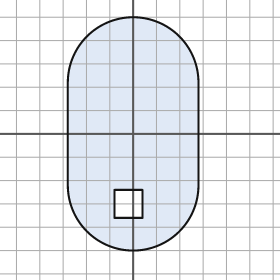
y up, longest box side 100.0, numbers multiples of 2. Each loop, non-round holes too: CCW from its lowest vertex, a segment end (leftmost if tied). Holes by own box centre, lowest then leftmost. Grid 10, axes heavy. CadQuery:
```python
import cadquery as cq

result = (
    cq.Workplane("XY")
    .moveTo(-28.0, -22.0)
    .threePointArc((0.0, -50.0), (28.0, -22.0))
    .lineTo(28.0, 22.0)
    .threePointArc((0.0, 50.0), (-28.0, 22.0))
    .close()
    .moveTo(-8.0, -36.0)
    .lineTo(4.0, -36.0)
    .lineTo(4.0, -24.0)
    .lineTo(-8.0, -24.0)
    .close()
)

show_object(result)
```